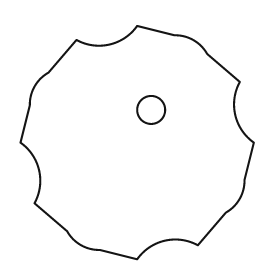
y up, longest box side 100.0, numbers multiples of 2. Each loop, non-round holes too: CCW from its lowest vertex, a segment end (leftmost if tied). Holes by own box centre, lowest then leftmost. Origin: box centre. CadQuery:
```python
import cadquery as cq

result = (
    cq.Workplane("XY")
    .moveTo(0.0, -50.0)
    .threePointArc((12.0, -42.0), (26.0, -44.0))
    .lineTo(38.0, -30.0)
    .threePointArc((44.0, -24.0), (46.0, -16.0))
    .lineTo(50.0, 0.0)
    .threePointArc((42.0, 12.0), (44.0, 26.0))
    .lineTo(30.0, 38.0)
    .threePointArc((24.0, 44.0), (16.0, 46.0))
    .lineTo(0.0, 50.0)
    .threePointArc((-12.0, 42.0), (-26.0, 44.0))
    .lineTo(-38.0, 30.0)
    .threePointArc((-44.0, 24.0), (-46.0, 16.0))
    .lineTo(-50.0, 0.0)
    .threePointArc((-42.0, -12.0), (-44.0, -26.0))
    .lineTo(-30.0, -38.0)
    .threePointArc((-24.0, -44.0), (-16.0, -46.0))
    .close()
    .moveTo(6.0, 14.0)
    .circle(6.0)
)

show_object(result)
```